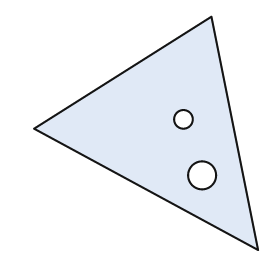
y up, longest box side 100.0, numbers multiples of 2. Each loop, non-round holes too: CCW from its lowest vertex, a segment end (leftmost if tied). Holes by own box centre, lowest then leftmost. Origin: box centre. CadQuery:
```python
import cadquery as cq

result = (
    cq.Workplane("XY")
    .moveTo(48.0, -50.0)
    .lineTo(28.0, 50.0)
    .lineTo(-48.0, 2.0)
    .close()
    .moveTo(24.0, -18.0)
    .circle(6.0)
    .moveTo(16.0, 6.0)
    .circle(4.0)
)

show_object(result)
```